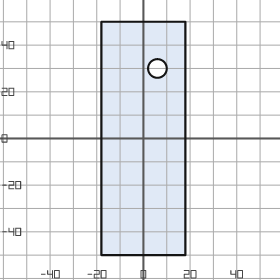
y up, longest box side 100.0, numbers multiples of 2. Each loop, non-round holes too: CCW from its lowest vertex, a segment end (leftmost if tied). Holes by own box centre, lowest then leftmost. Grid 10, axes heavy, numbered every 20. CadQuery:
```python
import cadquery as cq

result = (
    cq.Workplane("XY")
    .moveTo(-18.0, -50.0)
    .lineTo(18.0, -50.0)
    .lineTo(18.0, 50.0)
    .lineTo(-18.0, 50.0)
    .close()
    .moveTo(6.0, 30.0)
    .circle(4.0)
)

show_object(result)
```